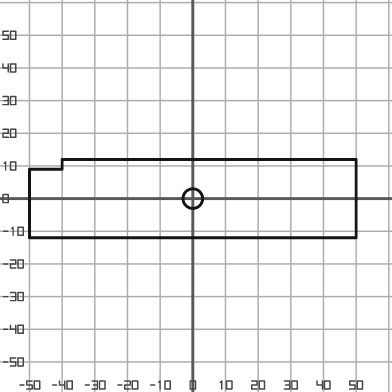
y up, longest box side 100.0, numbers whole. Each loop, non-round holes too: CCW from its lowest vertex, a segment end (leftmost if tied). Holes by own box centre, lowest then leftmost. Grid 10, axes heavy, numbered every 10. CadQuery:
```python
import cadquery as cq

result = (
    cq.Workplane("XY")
    .moveTo(-50.0, -12.0)
    .lineTo(50.0, -12.0)
    .lineTo(50.0, 12.0)
    .lineTo(-40.0, 12.0)
    .lineTo(-40.0, 9.0)
    .lineTo(-50.0, 9.0)
    .close()
    .moveTo(0.0, 0.0)
    .circle(3.0)
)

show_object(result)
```